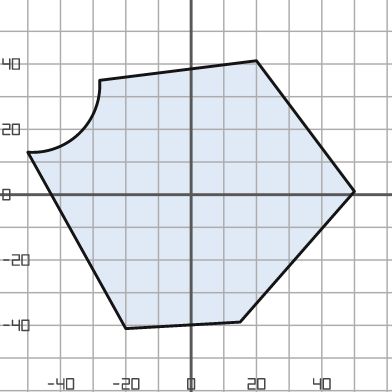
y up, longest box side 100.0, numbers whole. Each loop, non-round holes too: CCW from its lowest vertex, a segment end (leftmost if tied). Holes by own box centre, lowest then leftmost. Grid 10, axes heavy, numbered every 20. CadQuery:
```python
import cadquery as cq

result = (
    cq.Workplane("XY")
    .moveTo(-20.0, -41.0)
    .lineTo(15.0, -39.0)
    .lineTo(50.0, 1.0)
    .lineTo(20.0, 41.0)
    .lineTo(-28.0, 35.0)
    .threePointArc((-34.0, 19.0), (-50.0, 13.0))
    .close()
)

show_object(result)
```